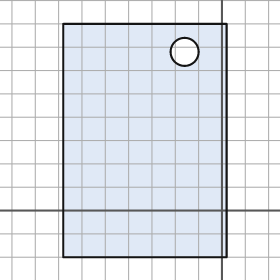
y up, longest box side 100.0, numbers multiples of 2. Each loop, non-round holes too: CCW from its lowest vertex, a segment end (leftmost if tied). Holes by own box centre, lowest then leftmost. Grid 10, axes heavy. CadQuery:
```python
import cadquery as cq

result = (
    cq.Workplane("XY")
    .moveTo(-68.0, -20.0)
    .lineTo(2.0, -20.0)
    .lineTo(2.0, 80.0)
    .lineTo(-68.0, 80.0)
    .close()
    .moveTo(-16.0, 68.0)
    .circle(6.0)
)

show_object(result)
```